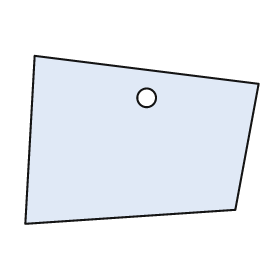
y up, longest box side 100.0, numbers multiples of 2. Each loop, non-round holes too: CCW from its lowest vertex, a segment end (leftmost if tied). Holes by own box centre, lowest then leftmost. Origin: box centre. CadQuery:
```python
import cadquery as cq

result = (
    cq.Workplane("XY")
    .moveTo(-50.0, -36.0)
    .lineTo(40.0, -30.0)
    .lineTo(50.0, 24.0)
    .lineTo(-46.0, 36.0)
    .close()
    .moveTo(2.0, 18.0)
    .circle(4.0)
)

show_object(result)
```